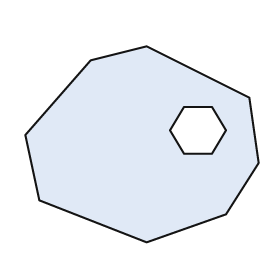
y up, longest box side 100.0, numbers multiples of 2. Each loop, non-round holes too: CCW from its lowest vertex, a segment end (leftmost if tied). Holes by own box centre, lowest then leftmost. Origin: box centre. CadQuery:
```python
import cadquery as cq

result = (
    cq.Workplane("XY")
    .moveTo(2.0, -42.0)
    .lineTo(36.0, -30.0)
    .lineTo(50.0, -8.0)
    .lineTo(46.0, 20.0)
    .lineTo(2.0, 42.0)
    .lineTo(-22.0, 36.0)
    .lineTo(-50.0, 4.0)
    .lineTo(-44.0, -24.0)
    .close()
    .moveTo(18.0, -4.0)
    .lineTo(30.0, -4.0)
    .lineTo(36.0, 6.0)
    .lineTo(30.0, 16.0)
    .lineTo(18.0, 16.0)
    .lineTo(12.0, 6.0)
    .close()
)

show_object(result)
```